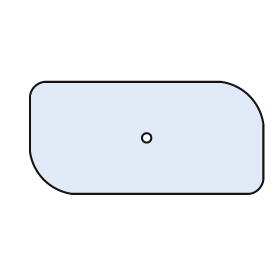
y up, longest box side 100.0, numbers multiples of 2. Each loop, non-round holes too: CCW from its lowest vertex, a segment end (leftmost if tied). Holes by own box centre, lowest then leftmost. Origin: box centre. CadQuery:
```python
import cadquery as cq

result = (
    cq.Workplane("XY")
    .moveTo(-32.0, -24.0)
    .lineTo(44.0, -24.0)
    .threePointArc((48.0, -22.0), (50.0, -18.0))
    .lineTo(50.0, 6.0)
    .threePointArc((44.0, 18.0), (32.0, 24.0))
    .lineTo(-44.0, 24.0)
    .threePointArc((-48.0, 22.0), (-50.0, 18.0))
    .lineTo(-50.0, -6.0)
    .threePointArc((-44.0, -18.0), (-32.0, -24.0))
    .close()
    .moveTo(0.0, 0.0)
    .circle(2.0)
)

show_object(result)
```